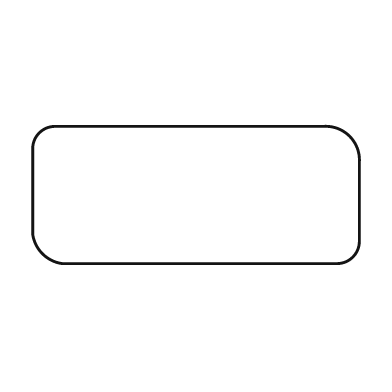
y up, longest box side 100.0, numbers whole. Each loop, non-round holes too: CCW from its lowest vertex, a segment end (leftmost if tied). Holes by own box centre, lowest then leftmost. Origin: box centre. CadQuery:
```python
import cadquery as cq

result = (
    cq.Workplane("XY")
    .moveTo(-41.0, -21.0)
    .lineTo(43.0, -21.0)
    .threePointArc((48.0, -19.0), (50.0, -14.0))
    .lineTo(50.0, 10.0)
    .threePointArc((47.0, 18.0), (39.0, 21.0))
    .lineTo(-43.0, 21.0)
    .threePointArc((-48.0, 19.0), (-50.0, 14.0))
    .lineTo(-50.0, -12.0)
    .threePointArc((-47.0, -18.0), (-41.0, -21.0))
    .close()
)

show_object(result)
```